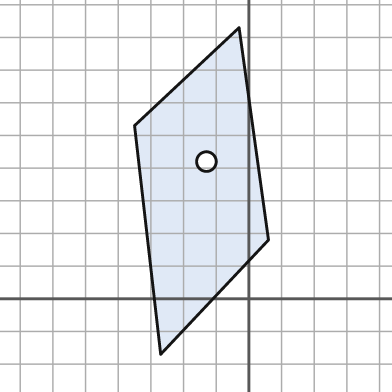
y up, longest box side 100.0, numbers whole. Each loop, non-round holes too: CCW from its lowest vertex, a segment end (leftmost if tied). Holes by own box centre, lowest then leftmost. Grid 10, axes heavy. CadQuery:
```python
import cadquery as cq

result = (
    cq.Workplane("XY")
    .moveTo(-27.0, -17.0)
    .lineTo(6.0, 18.0)
    .lineTo(-3.0, 83.0)
    .lineTo(-35.0, 53.0)
    .close()
    .moveTo(-13.0, 42.0)
    .circle(3.0)
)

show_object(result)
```